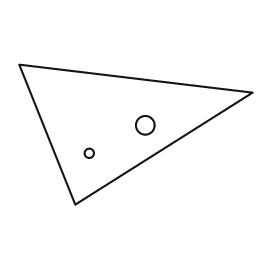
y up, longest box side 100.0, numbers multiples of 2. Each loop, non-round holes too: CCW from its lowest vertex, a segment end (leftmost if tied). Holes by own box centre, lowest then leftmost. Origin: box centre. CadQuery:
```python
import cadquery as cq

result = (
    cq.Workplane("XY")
    .moveTo(-26.0, -30.0)
    .lineTo(50.0, 18.0)
    .lineTo(-50.0, 30.0)
    .close()
    .moveTo(-20.0, -8.0)
    .circle(2.0)
    .moveTo(4.0, 4.0)
    .circle(4.0)
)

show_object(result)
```